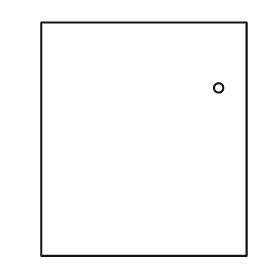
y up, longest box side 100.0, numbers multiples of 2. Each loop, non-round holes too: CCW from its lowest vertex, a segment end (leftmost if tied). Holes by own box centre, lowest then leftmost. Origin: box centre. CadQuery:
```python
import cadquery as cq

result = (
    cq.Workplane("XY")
    .moveTo(-44.0, -50.0)
    .lineTo(44.0, -50.0)
    .lineTo(44.0, 50.0)
    .lineTo(-44.0, 50.0)
    .close()
    .moveTo(32.0, 22.0)
    .circle(2.0)
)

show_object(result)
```